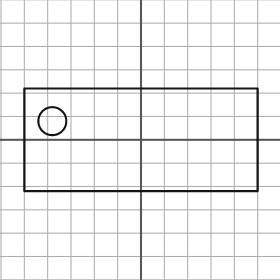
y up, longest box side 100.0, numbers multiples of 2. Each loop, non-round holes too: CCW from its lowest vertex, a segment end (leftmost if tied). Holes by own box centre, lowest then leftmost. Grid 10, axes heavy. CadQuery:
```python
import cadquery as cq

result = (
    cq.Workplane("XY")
    .moveTo(-50.0, -22.0)
    .lineTo(50.0, -22.0)
    .lineTo(50.0, 22.0)
    .lineTo(-50.0, 22.0)
    .close()
    .moveTo(-38.0, 8.0)
    .circle(6.0)
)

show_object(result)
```